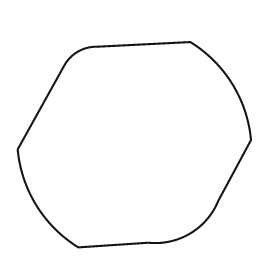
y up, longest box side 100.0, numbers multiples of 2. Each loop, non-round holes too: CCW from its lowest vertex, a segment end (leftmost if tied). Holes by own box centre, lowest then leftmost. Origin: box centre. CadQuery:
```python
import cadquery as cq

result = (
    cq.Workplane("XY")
    .moveTo(-24.0, -44.0)
    .lineTo(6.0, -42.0)
    .threePointArc((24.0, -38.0), (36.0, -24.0))
    .lineTo(50.0, 2.0)
    .threePointArc((42.0, 26.0), (24.0, 44.0))
    .lineTo(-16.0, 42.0)
    .threePointArc((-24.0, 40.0), (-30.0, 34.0))
    .lineTo(-50.0, -2.0)
    .threePointArc((-42.0, -26.0), (-24.0, -44.0))
    .close()
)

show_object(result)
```